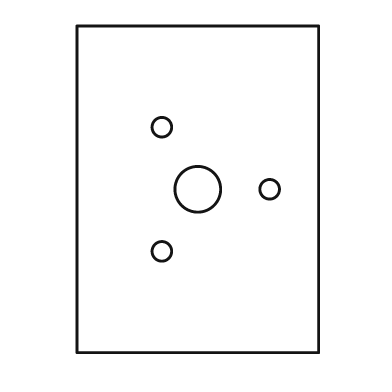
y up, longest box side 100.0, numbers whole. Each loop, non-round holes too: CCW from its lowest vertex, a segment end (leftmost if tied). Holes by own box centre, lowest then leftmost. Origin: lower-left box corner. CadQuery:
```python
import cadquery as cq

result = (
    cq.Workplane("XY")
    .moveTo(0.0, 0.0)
    .lineTo(74.0, 0.0)
    .lineTo(74.0, 100.0)
    .lineTo(0.0, 100.0)
    .close()
    .moveTo(26.0, 31.0)
    .circle(3.0)
    .moveTo(37.0, 50.0)
    .circle(7.0)
    .moveTo(59.0, 50.0)
    .circle(3.0)
    .moveTo(26.0, 69.0)
    .circle(3.0)
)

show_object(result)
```